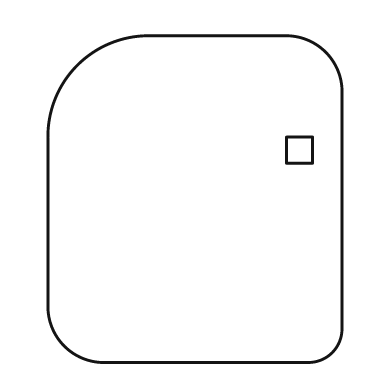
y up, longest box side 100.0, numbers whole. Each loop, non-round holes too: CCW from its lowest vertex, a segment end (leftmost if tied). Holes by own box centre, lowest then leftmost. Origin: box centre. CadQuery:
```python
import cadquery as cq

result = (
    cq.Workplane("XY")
    .moveTo(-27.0, -50.0)
    .lineTo(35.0, -50.0)
    .threePointArc((42.0, -47.0), (45.0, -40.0))
    .lineTo(45.0, 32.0)
    .threePointArc((40.0, 45.0), (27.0, 50.0))
    .lineTo(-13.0, 50.0)
    .threePointArc((-36.0, 41.0), (-45.0, 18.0))
    .lineTo(-45.0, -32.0)
    .threePointArc((-40.0, -45.0), (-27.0, -50.0))
    .close()
    .moveTo(28.0, 11.0)
    .lineTo(36.0, 11.0)
    .lineTo(36.0, 19.0)
    .lineTo(28.0, 19.0)
    .close()
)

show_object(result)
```